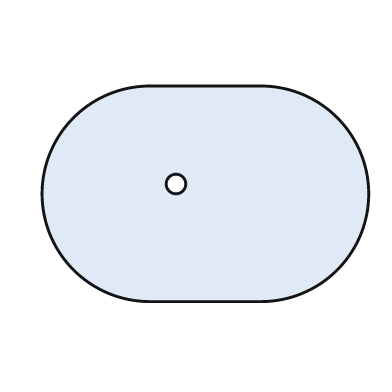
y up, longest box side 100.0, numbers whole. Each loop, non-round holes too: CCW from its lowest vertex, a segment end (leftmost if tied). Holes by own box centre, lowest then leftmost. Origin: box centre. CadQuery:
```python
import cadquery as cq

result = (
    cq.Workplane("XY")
    .moveTo(-17.0, -33.0)
    .lineTo(17.0, -33.0)
    .threePointArc((50.0, 0.0), (17.0, 33.0))
    .lineTo(-17.0, 33.0)
    .threePointArc((-50.0, 0.0), (-17.0, -33.0))
    .close()
    .moveTo(-9.0, 3.0)
    .circle(3.0)
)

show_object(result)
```